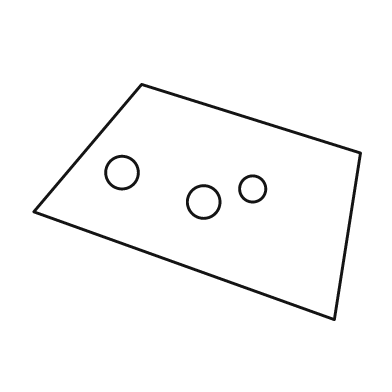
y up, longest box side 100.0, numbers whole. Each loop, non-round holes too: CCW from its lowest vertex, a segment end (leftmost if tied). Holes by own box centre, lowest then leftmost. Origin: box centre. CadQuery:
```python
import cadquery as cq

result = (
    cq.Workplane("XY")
    .moveTo(42.0, -36.0)
    .lineTo(50.0, 15.0)
    .lineTo(-17.0, 36.0)
    .lineTo(-50.0, -3.0)
    .close()
    .moveTo(2.0, 0.0)
    .circle(5.0)
    .moveTo(17.0, 4.0)
    .circle(4.0)
    .moveTo(-23.0, 9.0)
    .circle(5.0)
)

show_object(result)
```